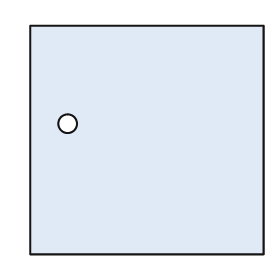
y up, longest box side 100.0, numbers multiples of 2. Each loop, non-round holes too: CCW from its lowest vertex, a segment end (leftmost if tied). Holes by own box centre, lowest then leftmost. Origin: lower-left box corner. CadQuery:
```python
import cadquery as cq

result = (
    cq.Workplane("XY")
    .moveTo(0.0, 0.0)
    .lineTo(100.0, 0.0)
    .lineTo(100.0, 98.0)
    .lineTo(0.0, 98.0)
    .close()
    .moveTo(16.0, 56.0)
    .circle(4.0)
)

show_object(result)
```